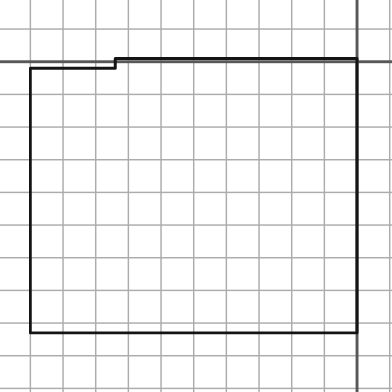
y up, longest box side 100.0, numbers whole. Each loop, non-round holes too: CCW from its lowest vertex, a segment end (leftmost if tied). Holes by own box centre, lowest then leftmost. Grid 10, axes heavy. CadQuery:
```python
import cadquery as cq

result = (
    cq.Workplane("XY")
    .moveTo(-100.0, -83.0)
    .lineTo(0.0, -83.0)
    .lineTo(0.0, 1.0)
    .lineTo(-74.0, 1.0)
    .lineTo(-74.0, -2.0)
    .lineTo(-100.0, -2.0)
    .close()
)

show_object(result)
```